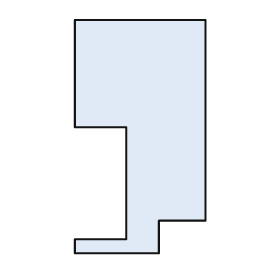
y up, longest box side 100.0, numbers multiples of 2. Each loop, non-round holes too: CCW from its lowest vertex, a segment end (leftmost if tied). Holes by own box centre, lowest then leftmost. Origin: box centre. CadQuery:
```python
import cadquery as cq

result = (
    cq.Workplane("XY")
    .moveTo(-28.0, -50.0)
    .lineTo(8.0, -50.0)
    .lineTo(8.0, -36.0)
    .lineTo(28.0, -36.0)
    .lineTo(28.0, 50.0)
    .lineTo(-28.0, 50.0)
    .lineTo(-28.0, 4.0)
    .lineTo(-6.0, 4.0)
    .lineTo(-6.0, -44.0)
    .lineTo(-28.0, -44.0)
    .close()
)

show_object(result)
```